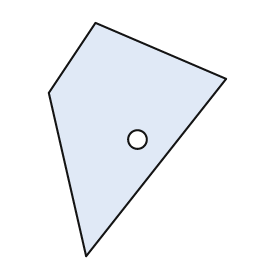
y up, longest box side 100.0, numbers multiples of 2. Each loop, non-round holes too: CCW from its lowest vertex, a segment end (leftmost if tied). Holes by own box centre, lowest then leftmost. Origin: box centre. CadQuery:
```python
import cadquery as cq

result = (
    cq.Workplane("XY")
    .moveTo(-22.0, -50.0)
    .lineTo(38.0, 26.0)
    .lineTo(-18.0, 50.0)
    .lineTo(-38.0, 20.0)
    .close()
    .moveTo(0.0, 0.0)
    .circle(4.0)
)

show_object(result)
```